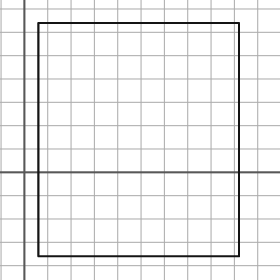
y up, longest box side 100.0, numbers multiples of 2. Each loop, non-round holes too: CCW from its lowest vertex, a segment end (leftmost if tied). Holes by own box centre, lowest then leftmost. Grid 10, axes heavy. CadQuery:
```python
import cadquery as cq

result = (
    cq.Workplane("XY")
    .moveTo(6.0, -36.0)
    .lineTo(92.0, -36.0)
    .lineTo(92.0, 64.0)
    .lineTo(6.0, 64.0)
    .close()
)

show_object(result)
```